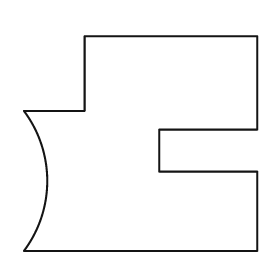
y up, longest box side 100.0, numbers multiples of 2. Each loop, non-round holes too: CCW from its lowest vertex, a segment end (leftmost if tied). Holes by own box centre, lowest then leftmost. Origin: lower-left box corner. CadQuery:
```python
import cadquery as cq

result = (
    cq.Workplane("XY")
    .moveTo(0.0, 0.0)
    .lineTo(100.0, 0.0)
    .lineTo(100.0, 34.0)
    .lineTo(58.0, 34.0)
    .lineTo(58.0, 52.0)
    .lineTo(100.0, 52.0)
    .lineTo(100.0, 92.0)
    .lineTo(26.0, 92.0)
    .lineTo(26.0, 60.0)
    .lineTo(0.0, 60.0)
    .threePointArc((10.0, 30.0), (0.0, 0.0))
    .close()
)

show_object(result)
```